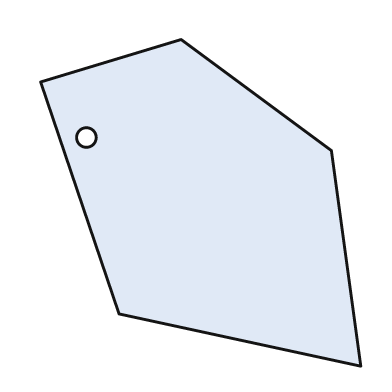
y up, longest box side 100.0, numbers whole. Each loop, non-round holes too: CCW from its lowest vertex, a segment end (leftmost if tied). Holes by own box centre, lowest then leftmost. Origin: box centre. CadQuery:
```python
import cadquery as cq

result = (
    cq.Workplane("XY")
    .moveTo(49.0, -50.0)
    .lineTo(40.0, 16.0)
    .lineTo(-6.0, 50.0)
    .lineTo(-49.0, 37.0)
    .lineTo(-25.0, -34.0)
    .close()
    .moveTo(-35.0, 20.0)
    .circle(3.0)
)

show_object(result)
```